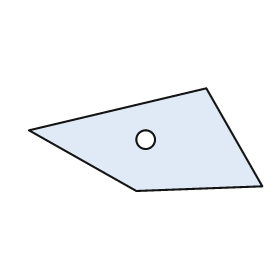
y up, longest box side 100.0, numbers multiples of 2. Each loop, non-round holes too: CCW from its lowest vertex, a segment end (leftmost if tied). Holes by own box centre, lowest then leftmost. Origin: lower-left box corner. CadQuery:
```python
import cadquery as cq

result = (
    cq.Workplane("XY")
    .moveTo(46.0, 0.0)
    .lineTo(100.0, 2.0)
    .lineTo(76.0, 44.0)
    .lineTo(0.0, 26.0)
    .close()
    .moveTo(50.0, 22.0)
    .circle(4.0)
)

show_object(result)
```